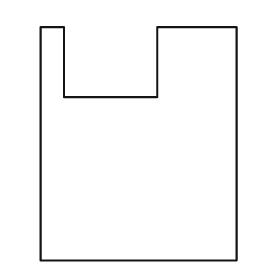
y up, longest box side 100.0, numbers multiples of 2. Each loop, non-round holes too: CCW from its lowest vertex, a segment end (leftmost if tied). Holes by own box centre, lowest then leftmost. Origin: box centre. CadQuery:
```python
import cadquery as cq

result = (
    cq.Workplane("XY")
    .moveTo(-42.0, -50.0)
    .lineTo(42.0, -50.0)
    .lineTo(42.0, 50.0)
    .lineTo(8.0, 50.0)
    .lineTo(8.0, 20.0)
    .lineTo(-32.0, 20.0)
    .lineTo(-32.0, 50.0)
    .lineTo(-42.0, 50.0)
    .close()
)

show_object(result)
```